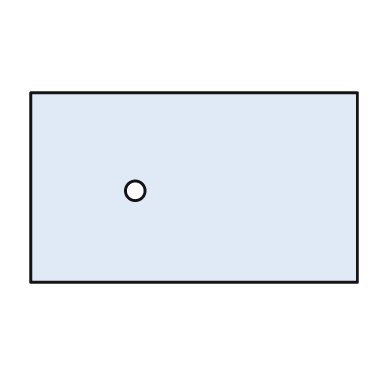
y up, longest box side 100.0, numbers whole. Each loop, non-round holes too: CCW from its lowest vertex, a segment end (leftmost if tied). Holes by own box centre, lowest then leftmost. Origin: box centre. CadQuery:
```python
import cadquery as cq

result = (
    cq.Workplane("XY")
    .moveTo(-50.0, -29.0)
    .lineTo(50.0, -29.0)
    .lineTo(50.0, 29.0)
    .lineTo(-50.0, 29.0)
    .close()
    .moveTo(-18.0, -1.0)
    .circle(3.0)
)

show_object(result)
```